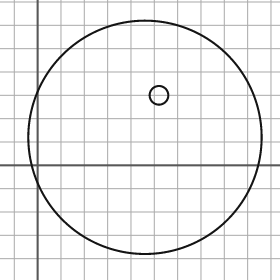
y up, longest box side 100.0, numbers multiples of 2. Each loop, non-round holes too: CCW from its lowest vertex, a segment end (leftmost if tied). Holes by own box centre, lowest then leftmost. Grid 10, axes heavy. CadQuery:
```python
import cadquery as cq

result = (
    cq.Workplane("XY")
    .moveTo(46.0, 12.0)
    .circle(50.0)
    .moveTo(52.0, 30.0)
    .circle(4.0)
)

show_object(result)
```